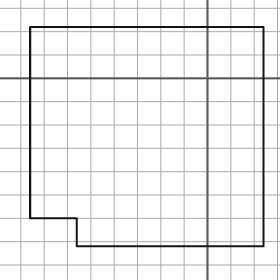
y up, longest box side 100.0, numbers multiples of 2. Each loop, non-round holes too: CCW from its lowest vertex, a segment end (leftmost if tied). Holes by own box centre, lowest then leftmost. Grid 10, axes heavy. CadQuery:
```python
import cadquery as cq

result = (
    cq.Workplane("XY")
    .moveTo(-56.0, -72.0)
    .lineTo(24.0, -72.0)
    .lineTo(24.0, 22.0)
    .lineTo(-76.0, 22.0)
    .lineTo(-76.0, -60.0)
    .lineTo(-56.0, -60.0)
    .close()
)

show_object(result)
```